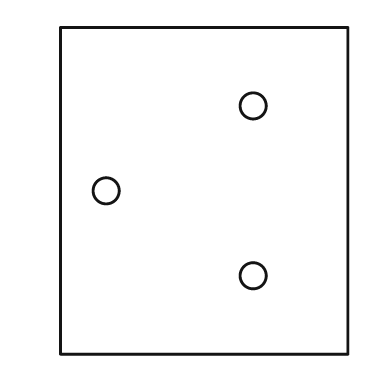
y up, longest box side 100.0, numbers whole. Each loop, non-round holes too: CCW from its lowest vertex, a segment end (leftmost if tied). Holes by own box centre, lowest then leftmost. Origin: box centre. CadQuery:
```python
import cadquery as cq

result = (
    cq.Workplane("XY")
    .moveTo(-44.0, -50.0)
    .lineTo(44.0, -50.0)
    .lineTo(44.0, 50.0)
    .lineTo(-44.0, 50.0)
    .close()
    .moveTo(15.0, -26.0)
    .circle(4.0)
    .moveTo(-30.0, 0.0)
    .circle(4.0)
    .moveTo(15.0, 26.0)
    .circle(4.0)
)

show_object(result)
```